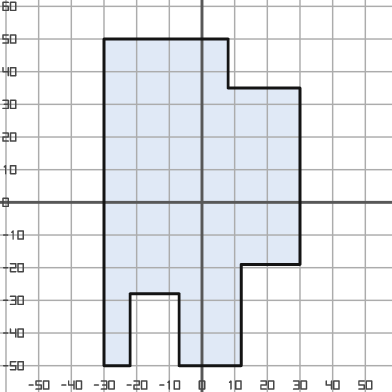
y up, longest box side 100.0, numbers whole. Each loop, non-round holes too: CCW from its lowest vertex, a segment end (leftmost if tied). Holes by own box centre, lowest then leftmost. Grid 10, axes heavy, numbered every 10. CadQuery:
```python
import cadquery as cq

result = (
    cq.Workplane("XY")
    .moveTo(-30.0, -50.0)
    .lineTo(-22.0, -50.0)
    .lineTo(-22.0, -28.0)
    .lineTo(-7.0, -28.0)
    .lineTo(-7.0, -50.0)
    .lineTo(12.0, -50.0)
    .lineTo(12.0, -19.0)
    .lineTo(30.0, -19.0)
    .lineTo(30.0, 35.0)
    .lineTo(8.0, 35.0)
    .lineTo(8.0, 50.0)
    .lineTo(-30.0, 50.0)
    .close()
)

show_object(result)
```